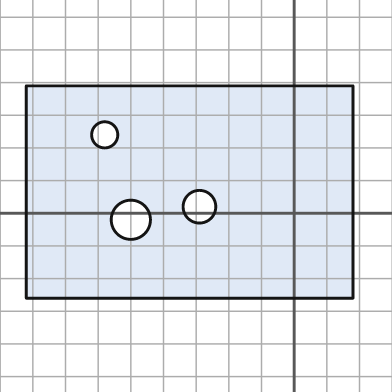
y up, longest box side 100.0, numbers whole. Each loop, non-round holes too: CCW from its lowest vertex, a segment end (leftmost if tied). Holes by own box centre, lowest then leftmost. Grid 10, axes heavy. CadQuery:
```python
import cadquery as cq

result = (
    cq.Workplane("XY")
    .moveTo(-82.0, -26.0)
    .lineTo(18.0, -26.0)
    .lineTo(18.0, 39.0)
    .lineTo(-82.0, 39.0)
    .close()
    .moveTo(-50.0, -2.0)
    .circle(6.0)
    .moveTo(-29.0, 2.0)
    .circle(5.0)
    .moveTo(-58.0, 24.0)
    .circle(4.0)
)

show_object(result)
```